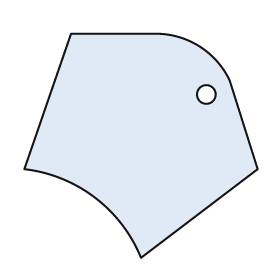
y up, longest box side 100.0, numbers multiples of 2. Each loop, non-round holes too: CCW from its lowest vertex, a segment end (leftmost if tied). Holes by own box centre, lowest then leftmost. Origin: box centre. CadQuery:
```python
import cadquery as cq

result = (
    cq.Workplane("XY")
    .moveTo(0.0, -48.0)
    .lineTo(50.0, -10.0)
    .lineTo(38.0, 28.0)
    .threePointArc((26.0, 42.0), (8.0, 48.0))
    .lineTo(-30.0, 48.0)
    .lineTo(-50.0, -10.0)
    .threePointArc((-20.0, -22.0), (0.0, -48.0))
    .close()
    .moveTo(28.0, 22.0)
    .circle(4.0)
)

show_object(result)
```